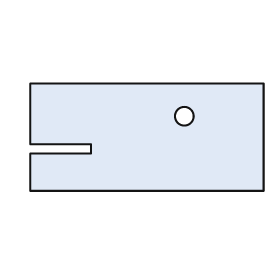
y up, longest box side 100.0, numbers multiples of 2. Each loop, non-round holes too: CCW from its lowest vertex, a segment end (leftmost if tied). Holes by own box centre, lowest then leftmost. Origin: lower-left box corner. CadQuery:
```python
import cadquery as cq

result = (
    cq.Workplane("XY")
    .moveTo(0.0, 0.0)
    .lineTo(100.0, 0.0)
    .lineTo(100.0, 46.0)
    .lineTo(0.0, 46.0)
    .lineTo(0.0, 20.0)
    .lineTo(26.0, 20.0)
    .lineTo(26.0, 16.0)
    .lineTo(0.0, 16.0)
    .close()
    .moveTo(66.0, 32.0)
    .circle(4.0)
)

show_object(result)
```